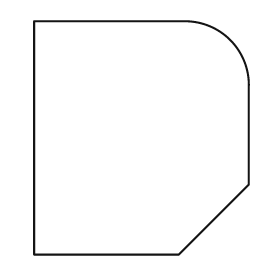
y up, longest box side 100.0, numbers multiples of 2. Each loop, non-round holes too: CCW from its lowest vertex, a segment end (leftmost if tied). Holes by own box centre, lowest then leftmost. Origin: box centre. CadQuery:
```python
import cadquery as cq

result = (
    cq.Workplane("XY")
    .moveTo(-46.0, -50.0)
    .lineTo(16.0, -50.0)
    .lineTo(46.0, -20.0)
    .lineTo(46.0, 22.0)
    .threePointArc((38.0, 42.0), (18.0, 50.0))
    .lineTo(-46.0, 50.0)
    .close()
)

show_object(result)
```